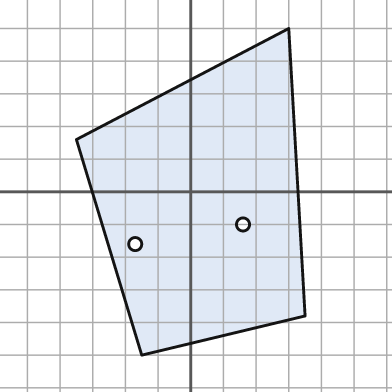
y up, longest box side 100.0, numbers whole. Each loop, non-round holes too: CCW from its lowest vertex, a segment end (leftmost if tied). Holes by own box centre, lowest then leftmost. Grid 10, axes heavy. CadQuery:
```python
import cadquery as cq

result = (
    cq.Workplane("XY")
    .moveTo(-15.0, -50.0)
    .lineTo(35.0, -38.0)
    .lineTo(30.0, 50.0)
    .lineTo(-35.0, 16.0)
    .close()
    .moveTo(-17.0, -16.0)
    .circle(2.0)
    .moveTo(16.0, -10.0)
    .circle(2.0)
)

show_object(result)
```